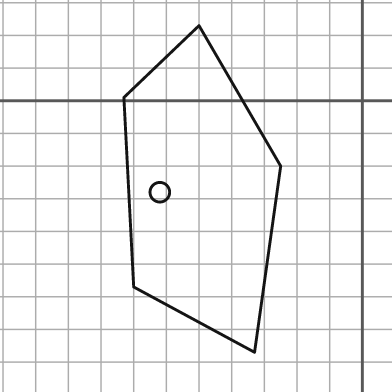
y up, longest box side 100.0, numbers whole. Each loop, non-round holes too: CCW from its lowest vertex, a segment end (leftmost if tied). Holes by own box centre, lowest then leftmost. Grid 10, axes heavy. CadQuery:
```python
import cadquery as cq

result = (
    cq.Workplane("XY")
    .moveTo(-33.0, -77.0)
    .lineTo(-25.0, -20.0)
    .lineTo(-50.0, 23.0)
    .lineTo(-73.0, 1.0)
    .lineTo(-70.0, -57.0)
    .close()
    .moveTo(-62.0, -28.0)
    .circle(3.0)
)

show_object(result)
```